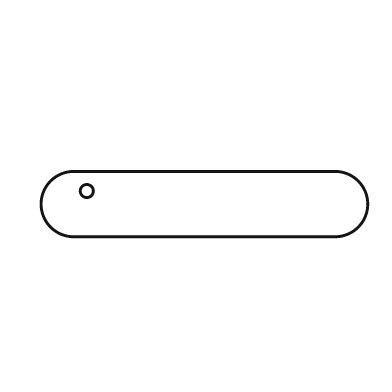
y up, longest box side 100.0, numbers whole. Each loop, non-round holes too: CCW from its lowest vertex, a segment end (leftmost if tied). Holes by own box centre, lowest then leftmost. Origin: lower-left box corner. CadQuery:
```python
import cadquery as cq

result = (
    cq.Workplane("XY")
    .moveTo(10.0, 0.0)
    .lineTo(90.0, 0.0)
    .threePointArc((100.0, 10.0), (90.0, 20.0))
    .lineTo(10.0, 20.0)
    .threePointArc((0.0, 10.0), (10.0, 0.0))
    .close()
    .moveTo(14.0, 14.0)
    .circle(2.0)
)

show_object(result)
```